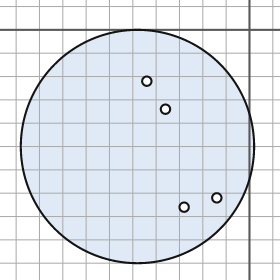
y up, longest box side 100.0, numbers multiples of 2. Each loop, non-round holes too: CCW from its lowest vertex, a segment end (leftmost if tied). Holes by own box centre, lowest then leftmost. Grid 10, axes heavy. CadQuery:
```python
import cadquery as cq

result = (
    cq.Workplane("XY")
    .moveTo(-48.0, -50.0)
    .circle(50.0)
    .moveTo(-28.0, -76.0)
    .circle(2.0)
    .moveTo(-14.0, -72.0)
    .circle(2.0)
    .moveTo(-36.0, -34.0)
    .circle(2.0)
    .moveTo(-44.0, -22.0)
    .circle(2.0)
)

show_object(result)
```